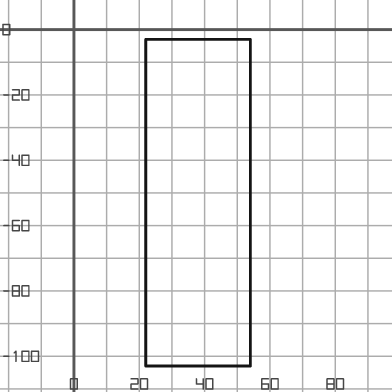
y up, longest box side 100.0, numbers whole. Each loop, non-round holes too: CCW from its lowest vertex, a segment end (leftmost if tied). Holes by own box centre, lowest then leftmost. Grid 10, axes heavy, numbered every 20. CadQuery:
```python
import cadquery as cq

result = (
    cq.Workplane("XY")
    .moveTo(22.0, -103.0)
    .lineTo(54.0, -103.0)
    .lineTo(54.0, -3.0)
    .lineTo(22.0, -3.0)
    .close()
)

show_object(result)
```